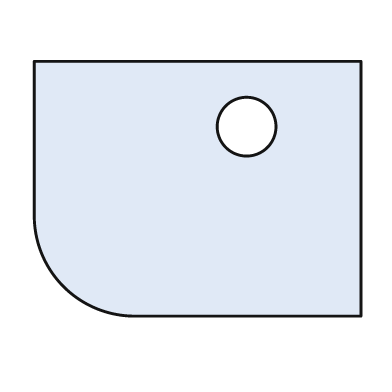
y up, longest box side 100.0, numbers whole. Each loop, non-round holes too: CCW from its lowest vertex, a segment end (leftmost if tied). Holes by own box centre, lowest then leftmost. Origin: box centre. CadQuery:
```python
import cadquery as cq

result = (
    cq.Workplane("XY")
    .moveTo(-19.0, -39.0)
    .lineTo(50.0, -39.0)
    .lineTo(50.0, 39.0)
    .lineTo(-50.0, 39.0)
    .lineTo(-50.0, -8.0)
    .threePointArc((-41.0, -30.0), (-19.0, -39.0))
    .close()
    .moveTo(15.0, 19.0)
    .circle(9.0)
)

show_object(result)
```